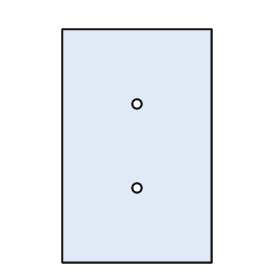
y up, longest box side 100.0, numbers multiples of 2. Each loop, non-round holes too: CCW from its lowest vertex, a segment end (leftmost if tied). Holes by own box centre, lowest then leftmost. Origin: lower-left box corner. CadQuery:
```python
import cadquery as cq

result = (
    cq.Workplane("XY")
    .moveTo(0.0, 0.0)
    .lineTo(64.0, 0.0)
    .lineTo(64.0, 100.0)
    .lineTo(0.0, 100.0)
    .close()
    .moveTo(32.0, 32.0)
    .circle(2.0)
    .moveTo(32.0, 68.0)
    .circle(2.0)
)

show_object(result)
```